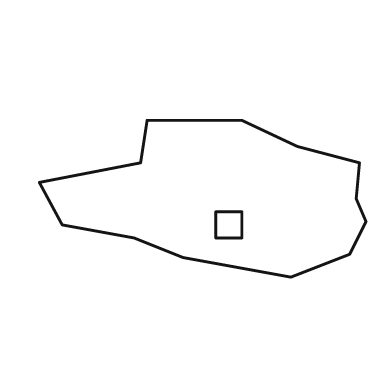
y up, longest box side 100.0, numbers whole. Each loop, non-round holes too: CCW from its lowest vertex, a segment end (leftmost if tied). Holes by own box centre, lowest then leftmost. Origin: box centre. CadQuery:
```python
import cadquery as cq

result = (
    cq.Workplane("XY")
    .moveTo(27.0, -24.0)
    .lineTo(45.0, -17.0)
    .lineTo(50.0, -7.0)
    .lineTo(47.0, 0.0)
    .lineTo(48.0, 11.0)
    .lineTo(29.0, 16.0)
    .lineTo(12.0, 24.0)
    .lineTo(-17.0, 24.0)
    .lineTo(-19.0, 11.0)
    .lineTo(-50.0, 5.0)
    .lineTo(-43.0, -8.0)
    .lineTo(-21.0, -12.0)
    .lineTo(-6.0, -18.0)
    .close()
    .moveTo(4.0, -12.0)
    .lineTo(12.0, -12.0)
    .lineTo(12.0, -4.0)
    .lineTo(4.0, -4.0)
    .close()
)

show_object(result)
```